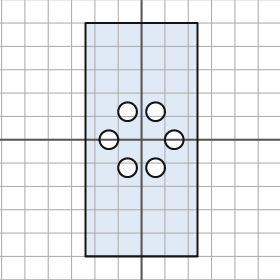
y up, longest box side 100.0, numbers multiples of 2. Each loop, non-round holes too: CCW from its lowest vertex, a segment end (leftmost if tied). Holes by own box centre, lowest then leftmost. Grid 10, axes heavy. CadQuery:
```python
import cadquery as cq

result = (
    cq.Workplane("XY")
    .moveTo(-24.0, -50.0)
    .lineTo(24.0, -50.0)
    .lineTo(24.0, 50.0)
    .lineTo(-24.0, 50.0)
    .close()
    .moveTo(-6.0, -12.0)
    .circle(4.0)
    .moveTo(6.0, -12.0)
    .circle(4.0)
    .moveTo(-14.0, 0.0)
    .circle(4.0)
    .moveTo(14.0, 0.0)
    .circle(4.0)
    .moveTo(-6.0, 12.0)
    .circle(4.0)
    .moveTo(6.0, 12.0)
    .circle(4.0)
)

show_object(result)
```